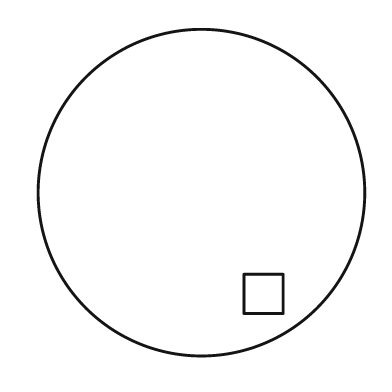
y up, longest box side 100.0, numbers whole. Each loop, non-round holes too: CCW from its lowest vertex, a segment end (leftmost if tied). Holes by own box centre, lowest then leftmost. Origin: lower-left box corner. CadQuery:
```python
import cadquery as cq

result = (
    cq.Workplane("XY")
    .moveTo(50.0, 50.0)
    .circle(50.0)
    .moveTo(63.0, 13.0)
    .lineTo(75.0, 13.0)
    .lineTo(75.0, 25.0)
    .lineTo(63.0, 25.0)
    .close()
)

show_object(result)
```